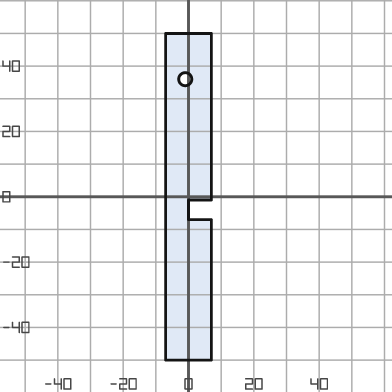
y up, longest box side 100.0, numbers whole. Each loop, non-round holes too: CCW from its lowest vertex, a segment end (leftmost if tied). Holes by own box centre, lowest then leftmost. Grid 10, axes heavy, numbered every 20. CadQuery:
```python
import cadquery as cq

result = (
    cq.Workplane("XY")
    .moveTo(-7.0, -50.0)
    .lineTo(7.0, -50.0)
    .lineTo(7.0, -7.0)
    .lineTo(0.0, -7.0)
    .lineTo(0.0, -1.0)
    .lineTo(7.0, -1.0)
    .lineTo(7.0, 50.0)
    .lineTo(-7.0, 50.0)
    .close()
    .moveTo(-1.0, 36.0)
    .circle(2.0)
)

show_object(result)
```